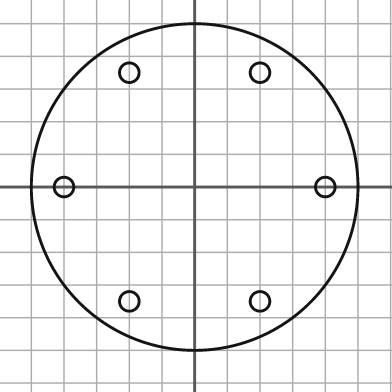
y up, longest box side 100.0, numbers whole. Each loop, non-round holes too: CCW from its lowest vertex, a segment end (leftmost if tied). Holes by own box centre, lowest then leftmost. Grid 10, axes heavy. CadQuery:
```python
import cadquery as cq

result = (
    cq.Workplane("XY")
    .moveTo(0.0, 0.0)
    .circle(50.0)
    .moveTo(-20.0, -35.0)
    .circle(3.0)
    .moveTo(20.0, -35.0)
    .circle(3.0)
    .moveTo(-40.0, 0.0)
    .circle(3.0)
    .moveTo(40.0, 0.0)
    .circle(3.0)
    .moveTo(-20.0, 35.0)
    .circle(3.0)
    .moveTo(20.0, 35.0)
    .circle(3.0)
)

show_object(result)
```